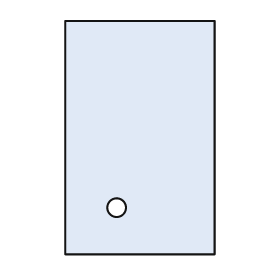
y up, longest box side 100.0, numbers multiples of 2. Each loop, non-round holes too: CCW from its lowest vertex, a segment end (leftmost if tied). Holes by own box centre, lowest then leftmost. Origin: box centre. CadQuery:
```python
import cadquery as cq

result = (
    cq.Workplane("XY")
    .moveTo(-32.0, -50.0)
    .lineTo(32.0, -50.0)
    .lineTo(32.0, 50.0)
    .lineTo(-32.0, 50.0)
    .close()
    .moveTo(-10.0, -30.0)
    .circle(4.0)
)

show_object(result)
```